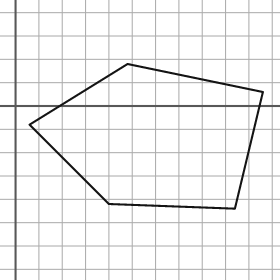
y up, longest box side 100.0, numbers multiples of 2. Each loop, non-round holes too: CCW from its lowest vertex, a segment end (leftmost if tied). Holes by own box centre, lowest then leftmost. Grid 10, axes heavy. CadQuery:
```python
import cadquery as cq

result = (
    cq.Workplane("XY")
    .moveTo(94.0, -44.0)
    .lineTo(106.0, 6.0)
    .lineTo(48.0, 18.0)
    .lineTo(6.0, -8.0)
    .lineTo(40.0, -42.0)
    .close()
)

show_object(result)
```